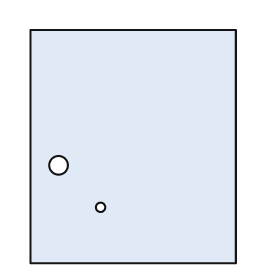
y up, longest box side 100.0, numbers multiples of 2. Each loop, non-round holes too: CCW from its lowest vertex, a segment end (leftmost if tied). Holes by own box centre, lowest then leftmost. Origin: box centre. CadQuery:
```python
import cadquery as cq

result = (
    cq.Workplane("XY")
    .moveTo(-44.0, -50.0)
    .lineTo(44.0, -50.0)
    .lineTo(44.0, 50.0)
    .lineTo(-44.0, 50.0)
    .close()
    .moveTo(-14.0, -26.0)
    .circle(2.0)
    .moveTo(-32.0, -8.0)
    .circle(4.0)
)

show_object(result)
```